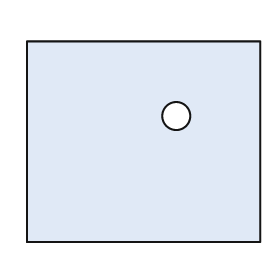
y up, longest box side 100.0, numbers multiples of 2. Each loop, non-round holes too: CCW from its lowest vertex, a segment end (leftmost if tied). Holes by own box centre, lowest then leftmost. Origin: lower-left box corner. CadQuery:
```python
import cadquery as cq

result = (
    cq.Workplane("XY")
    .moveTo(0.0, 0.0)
    .lineTo(100.0, 0.0)
    .lineTo(100.0, 86.0)
    .lineTo(0.0, 86.0)
    .close()
    .moveTo(64.0, 54.0)
    .circle(6.0)
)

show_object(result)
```